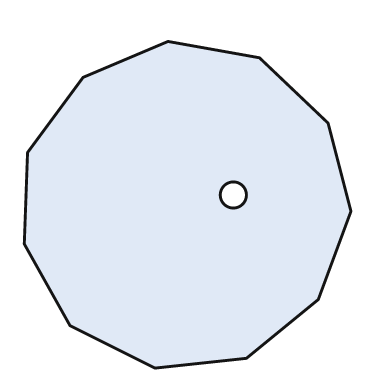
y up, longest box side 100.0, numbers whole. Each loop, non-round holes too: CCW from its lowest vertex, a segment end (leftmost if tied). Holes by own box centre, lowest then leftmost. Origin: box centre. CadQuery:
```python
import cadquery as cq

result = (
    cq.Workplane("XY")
    .moveTo(-10.0, -50.0)
    .lineTo(18.0, -47.0)
    .lineTo(40.0, -29.0)
    .lineTo(50.0, -2.0)
    .lineTo(43.0, 25.0)
    .lineTo(22.0, 45.0)
    .lineTo(-6.0, 50.0)
    .lineTo(-32.0, 39.0)
    .lineTo(-49.0, 16.0)
    .lineTo(-50.0, -12.0)
    .lineTo(-36.0, -37.0)
    .close()
    .moveTo(14.0, 3.0)
    .circle(4.0)
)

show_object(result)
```